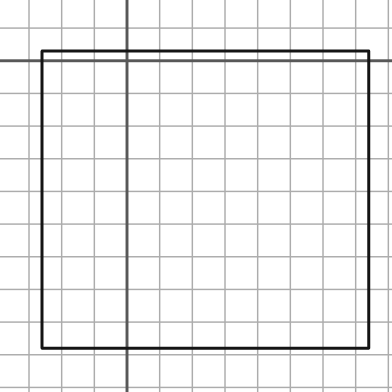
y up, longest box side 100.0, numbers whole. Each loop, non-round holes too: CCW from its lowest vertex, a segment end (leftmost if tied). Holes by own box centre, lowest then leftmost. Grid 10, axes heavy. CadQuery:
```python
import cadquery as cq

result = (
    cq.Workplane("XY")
    .moveTo(-26.0, -88.0)
    .lineTo(74.0, -88.0)
    .lineTo(74.0, 3.0)
    .lineTo(-26.0, 3.0)
    .close()
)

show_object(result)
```